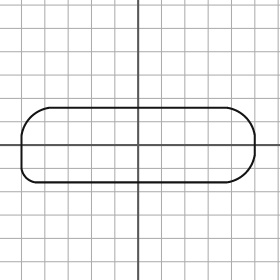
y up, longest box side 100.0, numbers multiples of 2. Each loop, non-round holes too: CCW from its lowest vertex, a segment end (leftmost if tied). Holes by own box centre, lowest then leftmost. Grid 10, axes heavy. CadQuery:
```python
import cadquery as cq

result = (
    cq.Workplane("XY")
    .moveTo(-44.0, -16.0)
    .lineTo(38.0, -16.0)
    .threePointArc((46.0, -12.0), (50.0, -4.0))
    .lineTo(50.0, 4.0)
    .threePointArc((46.0, 12.0), (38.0, 16.0))
    .lineTo(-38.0, 16.0)
    .threePointArc((-46.0, 12.0), (-50.0, 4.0))
    .lineTo(-50.0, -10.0)
    .threePointArc((-48.0, -14.0), (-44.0, -16.0))
    .close()
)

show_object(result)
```